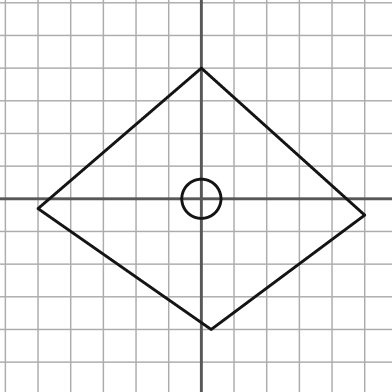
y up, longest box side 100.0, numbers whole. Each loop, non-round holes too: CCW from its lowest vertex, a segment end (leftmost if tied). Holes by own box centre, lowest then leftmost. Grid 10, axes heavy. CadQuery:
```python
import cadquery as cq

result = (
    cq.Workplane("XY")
    .moveTo(3.0, -40.0)
    .lineTo(50.0, -5.0)
    .lineTo(0.0, 40.0)
    .lineTo(-50.0, -3.0)
    .close()
    .moveTo(0.0, 0.0)
    .circle(6.0)
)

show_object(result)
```